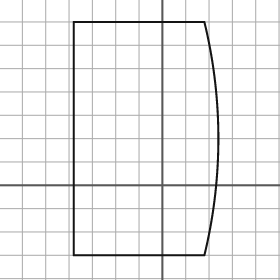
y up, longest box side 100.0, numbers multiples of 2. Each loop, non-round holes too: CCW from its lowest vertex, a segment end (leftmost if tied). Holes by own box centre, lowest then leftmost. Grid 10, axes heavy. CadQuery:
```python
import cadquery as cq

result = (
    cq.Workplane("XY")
    .moveTo(-38.0, -30.0)
    .lineTo(18.0, -30.0)
    .threePointArc((24.0, 20.0), (18.0, 70.0))
    .lineTo(-38.0, 70.0)
    .close()
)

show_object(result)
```